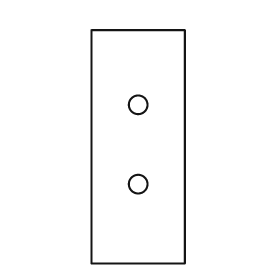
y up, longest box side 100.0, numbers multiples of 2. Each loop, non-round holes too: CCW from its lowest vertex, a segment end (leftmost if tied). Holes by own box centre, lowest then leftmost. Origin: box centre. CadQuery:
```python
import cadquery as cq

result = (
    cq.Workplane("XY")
    .moveTo(-20.0, -50.0)
    .lineTo(20.0, -50.0)
    .lineTo(20.0, 50.0)
    .lineTo(-20.0, 50.0)
    .close()
    .moveTo(0.0, -16.0)
    .circle(4.0)
    .moveTo(0.0, 18.0)
    .circle(4.0)
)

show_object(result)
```